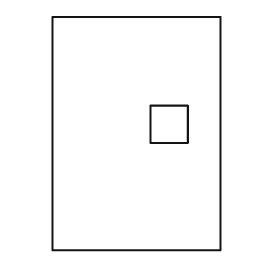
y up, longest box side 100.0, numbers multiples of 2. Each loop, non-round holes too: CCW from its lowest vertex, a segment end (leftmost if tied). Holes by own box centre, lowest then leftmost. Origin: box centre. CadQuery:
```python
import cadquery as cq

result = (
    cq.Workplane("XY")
    .moveTo(-36.0, -50.0)
    .lineTo(36.0, -50.0)
    .lineTo(36.0, 50.0)
    .lineTo(-36.0, 50.0)
    .close()
    .moveTo(6.0, -4.0)
    .lineTo(22.0, -4.0)
    .lineTo(22.0, 12.0)
    .lineTo(6.0, 12.0)
    .close()
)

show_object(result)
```